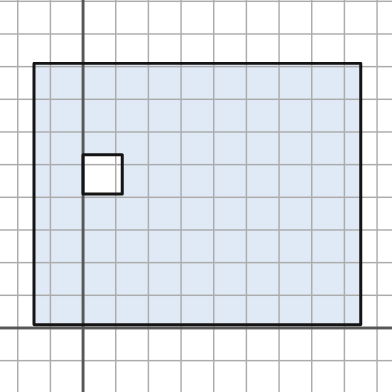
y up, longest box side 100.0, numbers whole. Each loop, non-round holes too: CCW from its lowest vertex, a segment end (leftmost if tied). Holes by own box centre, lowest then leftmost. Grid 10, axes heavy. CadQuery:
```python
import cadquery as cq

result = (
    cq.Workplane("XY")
    .moveTo(-15.0, 1.0)
    .lineTo(85.0, 1.0)
    .lineTo(85.0, 81.0)
    .lineTo(-15.0, 81.0)
    .close()
    .moveTo(0.0, 41.0)
    .lineTo(12.0, 41.0)
    .lineTo(12.0, 53.0)
    .lineTo(0.0, 53.0)
    .close()
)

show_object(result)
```